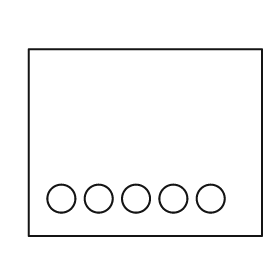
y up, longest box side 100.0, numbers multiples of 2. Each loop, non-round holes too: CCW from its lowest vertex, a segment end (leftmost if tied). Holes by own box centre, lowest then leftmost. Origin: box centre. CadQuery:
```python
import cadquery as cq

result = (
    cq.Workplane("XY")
    .moveTo(-50.0, -40.0)
    .lineTo(50.0, -40.0)
    .lineTo(50.0, 40.0)
    .lineTo(-50.0, 40.0)
    .close()
    .moveTo(-36.0, -24.0)
    .circle(6.0)
    .moveTo(-20.0, -24.0)
    .circle(6.0)
    .moveTo(-4.0, -24.0)
    .circle(6.0)
    .moveTo(12.0, -24.0)
    .circle(6.0)
    .moveTo(28.0, -24.0)
    .circle(6.0)
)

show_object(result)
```